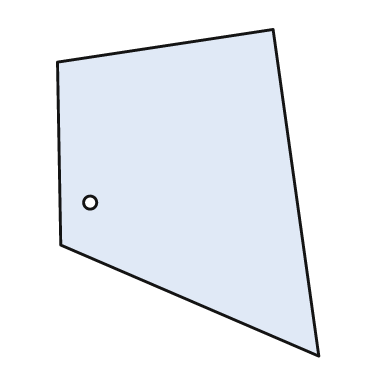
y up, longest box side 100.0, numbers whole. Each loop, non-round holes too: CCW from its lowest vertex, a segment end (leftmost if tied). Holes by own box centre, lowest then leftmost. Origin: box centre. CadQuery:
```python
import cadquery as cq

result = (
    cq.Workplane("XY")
    .moveTo(40.0, -50.0)
    .lineTo(26.0, 50.0)
    .lineTo(-40.0, 40.0)
    .lineTo(-39.0, -16.0)
    .close()
    .moveTo(-30.0, -3.0)
    .circle(2.0)
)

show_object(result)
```